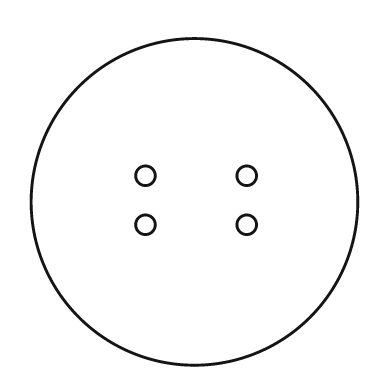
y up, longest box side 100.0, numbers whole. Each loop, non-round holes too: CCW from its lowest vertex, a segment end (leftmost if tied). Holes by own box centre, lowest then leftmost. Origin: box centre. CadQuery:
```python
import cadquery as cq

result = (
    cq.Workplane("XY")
    .moveTo(0.0, 0.0)
    .circle(50.0)
    .moveTo(-15.0, -7.0)
    .circle(3.0)
    .moveTo(16.0, -7.0)
    .circle(3.0)
    .moveTo(-15.0, 8.0)
    .circle(3.0)
    .moveTo(16.0, 8.0)
    .circle(3.0)
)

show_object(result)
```